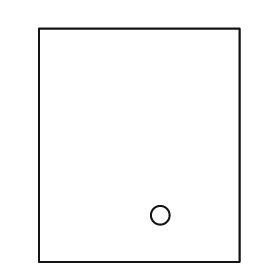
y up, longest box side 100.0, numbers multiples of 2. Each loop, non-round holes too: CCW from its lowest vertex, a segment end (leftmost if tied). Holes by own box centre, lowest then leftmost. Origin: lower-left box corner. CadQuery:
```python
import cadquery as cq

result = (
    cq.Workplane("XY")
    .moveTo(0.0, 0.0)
    .lineTo(86.0, 0.0)
    .lineTo(86.0, 100.0)
    .lineTo(0.0, 100.0)
    .close()
    .moveTo(52.0, 20.0)
    .circle(4.0)
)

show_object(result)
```